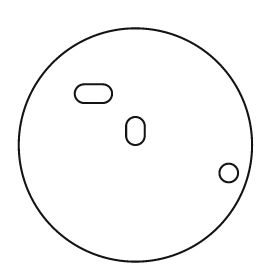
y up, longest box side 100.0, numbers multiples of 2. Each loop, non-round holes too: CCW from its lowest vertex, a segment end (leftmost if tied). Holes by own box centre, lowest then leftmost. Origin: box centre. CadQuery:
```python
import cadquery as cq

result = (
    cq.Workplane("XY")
    .moveTo(0.0, 0.0)
    .circle(50.0)
    .moveTo(40.0, -12.0)
    .circle(4.0)
    .moveTo(-4.0, 4.0)
    .threePointArc((0.0, 0.0), (4.0, 4.0))
    .lineTo(4.0, 8.0)
    .threePointArc((0.0, 12.0), (-4.0, 8.0))
    .close()
    .moveTo(-22.0, 18.0)
    .lineTo(-14.0, 18.0)
    .threePointArc((-10.0, 22.0), (-14.0, 26.0))
    .lineTo(-22.0, 26.0)
    .threePointArc((-26.0, 22.0), (-22.0, 18.0))
    .close()
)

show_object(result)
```